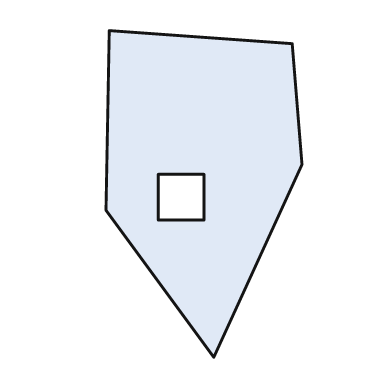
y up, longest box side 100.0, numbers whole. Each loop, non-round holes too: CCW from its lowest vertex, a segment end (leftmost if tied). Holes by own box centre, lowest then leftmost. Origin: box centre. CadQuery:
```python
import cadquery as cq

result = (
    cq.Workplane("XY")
    .moveTo(3.0, -50.0)
    .lineTo(30.0, 9.0)
    .lineTo(27.0, 46.0)
    .lineTo(-29.0, 50.0)
    .lineTo(-30.0, -5.0)
    .close()
    .moveTo(-14.0, -8.0)
    .lineTo(0.0, -8.0)
    .lineTo(0.0, 6.0)
    .lineTo(-14.0, 6.0)
    .close()
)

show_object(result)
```